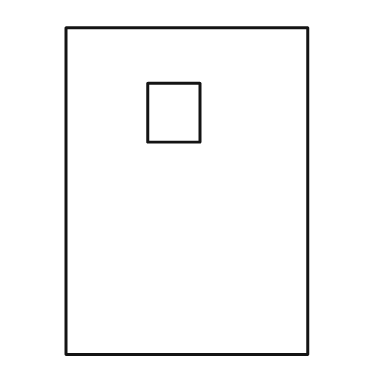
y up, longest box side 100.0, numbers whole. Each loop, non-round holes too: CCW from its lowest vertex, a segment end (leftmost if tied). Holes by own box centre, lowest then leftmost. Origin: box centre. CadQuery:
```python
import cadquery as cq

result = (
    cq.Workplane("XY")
    .moveTo(-37.0, -50.0)
    .lineTo(37.0, -50.0)
    .lineTo(37.0, 50.0)
    .lineTo(-37.0, 50.0)
    .close()
    .moveTo(-12.0, 15.0)
    .lineTo(4.0, 15.0)
    .lineTo(4.0, 33.0)
    .lineTo(-12.0, 33.0)
    .close()
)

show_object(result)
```